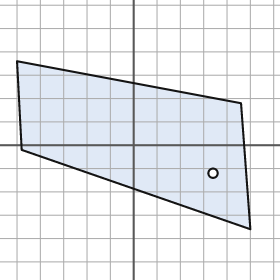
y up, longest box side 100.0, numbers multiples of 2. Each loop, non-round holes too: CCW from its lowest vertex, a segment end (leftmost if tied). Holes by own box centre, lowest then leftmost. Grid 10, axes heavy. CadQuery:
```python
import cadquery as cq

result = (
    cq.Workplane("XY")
    .moveTo(50.0, -36.0)
    .lineTo(46.0, 18.0)
    .lineTo(-50.0, 36.0)
    .lineTo(-48.0, -2.0)
    .close()
    .moveTo(34.0, -12.0)
    .circle(2.0)
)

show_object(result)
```